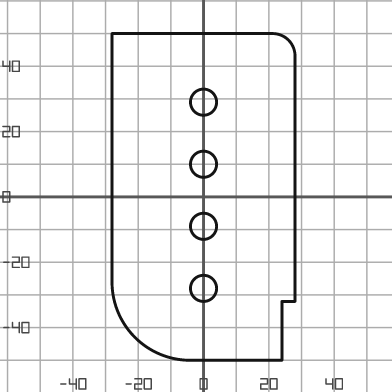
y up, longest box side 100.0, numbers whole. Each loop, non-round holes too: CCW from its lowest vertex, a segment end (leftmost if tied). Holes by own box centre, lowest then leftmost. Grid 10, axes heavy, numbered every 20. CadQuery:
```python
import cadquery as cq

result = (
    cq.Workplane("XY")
    .moveTo(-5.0, -50.0)
    .lineTo(24.0, -50.0)
    .lineTo(24.0, -32.0)
    .lineTo(28.0, -32.0)
    .lineTo(28.0, 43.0)
    .threePointArc((26.0, 48.0), (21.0, 50.0))
    .lineTo(-28.0, 50.0)
    .lineTo(-28.0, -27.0)
    .threePointArc((-21.0, -43.0), (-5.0, -50.0))
    .close()
    .moveTo(0.0, -28.0)
    .circle(4.0)
    .moveTo(0.0, -9.0)
    .circle(4.0)
    .moveTo(0.0, 10.0)
    .circle(4.0)
    .moveTo(0.0, 29.0)
    .circle(4.0)
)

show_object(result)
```